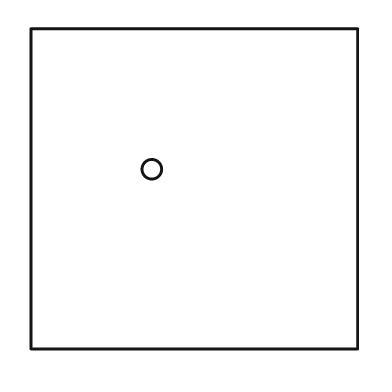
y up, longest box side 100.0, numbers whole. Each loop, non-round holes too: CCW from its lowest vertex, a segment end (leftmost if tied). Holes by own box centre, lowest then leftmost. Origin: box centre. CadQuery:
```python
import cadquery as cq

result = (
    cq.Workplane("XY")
    .moveTo(-50.0, -49.0)
    .lineTo(50.0, -49.0)
    .lineTo(50.0, 49.0)
    .lineTo(-50.0, 49.0)
    .close()
    .moveTo(-13.0, 6.0)
    .circle(3.0)
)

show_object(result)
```